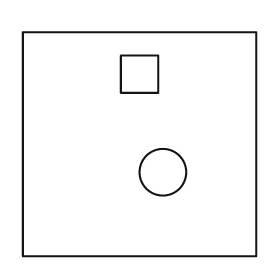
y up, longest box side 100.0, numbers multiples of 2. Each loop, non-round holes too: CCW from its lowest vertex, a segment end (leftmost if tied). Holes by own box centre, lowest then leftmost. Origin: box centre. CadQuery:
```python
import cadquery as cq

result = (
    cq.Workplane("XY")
    .moveTo(-50.0, -48.0)
    .lineTo(50.0, -48.0)
    .lineTo(50.0, 48.0)
    .lineTo(-50.0, 48.0)
    .close()
    .moveTo(10.0, -12.0)
    .circle(10.0)
    .moveTo(-8.0, 22.0)
    .lineTo(8.0, 22.0)
    .lineTo(8.0, 38.0)
    .lineTo(-8.0, 38.0)
    .close()
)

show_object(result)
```